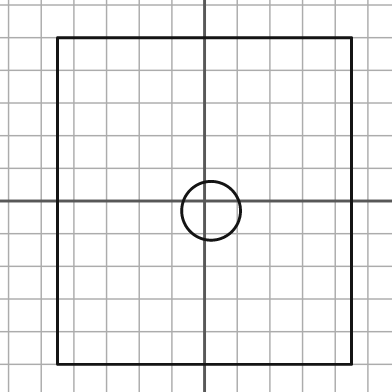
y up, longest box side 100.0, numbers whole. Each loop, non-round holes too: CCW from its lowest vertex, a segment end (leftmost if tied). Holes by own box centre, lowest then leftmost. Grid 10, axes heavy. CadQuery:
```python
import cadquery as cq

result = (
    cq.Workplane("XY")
    .moveTo(-45.0, -50.0)
    .lineTo(45.0, -50.0)
    .lineTo(45.0, 50.0)
    .lineTo(-45.0, 50.0)
    .close()
    .moveTo(2.0, -3.0)
    .circle(9.0)
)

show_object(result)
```